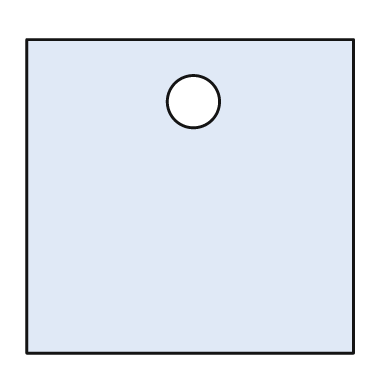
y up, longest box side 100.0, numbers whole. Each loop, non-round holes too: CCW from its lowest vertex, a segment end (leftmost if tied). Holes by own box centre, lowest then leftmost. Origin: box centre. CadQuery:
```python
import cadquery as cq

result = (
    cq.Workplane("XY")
    .moveTo(-50.0, -48.0)
    .lineTo(50.0, -48.0)
    .lineTo(50.0, 48.0)
    .lineTo(-50.0, 48.0)
    .close()
    .moveTo(1.0, 29.0)
    .circle(8.0)
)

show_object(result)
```